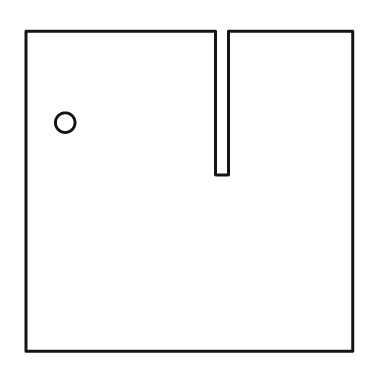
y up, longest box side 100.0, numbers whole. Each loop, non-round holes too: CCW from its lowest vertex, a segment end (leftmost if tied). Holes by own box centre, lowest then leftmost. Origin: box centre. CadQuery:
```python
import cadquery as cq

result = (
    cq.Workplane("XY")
    .moveTo(-50.0, -49.0)
    .lineTo(50.0, -49.0)
    .lineTo(50.0, 49.0)
    .lineTo(12.0, 49.0)
    .lineTo(12.0, 5.0)
    .lineTo(8.0, 5.0)
    .lineTo(8.0, 49.0)
    .lineTo(-50.0, 49.0)
    .close()
    .moveTo(-38.0, 21.0)
    .circle(3.0)
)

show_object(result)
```